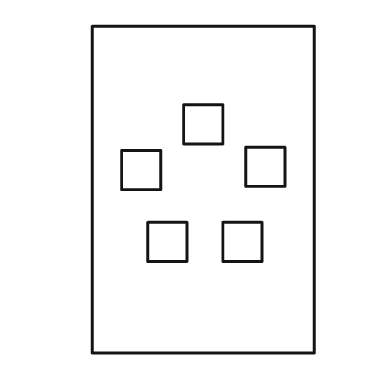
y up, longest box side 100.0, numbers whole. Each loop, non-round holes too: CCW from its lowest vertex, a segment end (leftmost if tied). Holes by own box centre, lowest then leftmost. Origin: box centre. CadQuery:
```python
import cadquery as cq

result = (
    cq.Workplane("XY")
    .moveTo(-34.0, -50.0)
    .lineTo(34.0, -50.0)
    .lineTo(34.0, 50.0)
    .lineTo(-34.0, 50.0)
    .close()
    .moveTo(-17.0, -22.0)
    .lineTo(-5.0, -22.0)
    .lineTo(-5.0, -10.0)
    .lineTo(-17.0, -10.0)
    .close()
    .moveTo(6.0, -22.0)
    .lineTo(18.0, -22.0)
    .lineTo(18.0, -10.0)
    .lineTo(6.0, -10.0)
    .close()
    .moveTo(-25.0, 0.0)
    .lineTo(-13.0, 0.0)
    .lineTo(-13.0, 12.0)
    .lineTo(-25.0, 12.0)
    .close()
    .moveTo(13.0, 1.0)
    .lineTo(25.0, 1.0)
    .lineTo(25.0, 13.0)
    .lineTo(13.0, 13.0)
    .close()
    .moveTo(-6.0, 14.0)
    .lineTo(6.0, 14.0)
    .lineTo(6.0, 26.0)
    .lineTo(-6.0, 26.0)
    .close()
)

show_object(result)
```